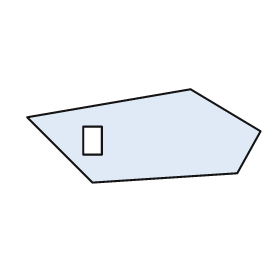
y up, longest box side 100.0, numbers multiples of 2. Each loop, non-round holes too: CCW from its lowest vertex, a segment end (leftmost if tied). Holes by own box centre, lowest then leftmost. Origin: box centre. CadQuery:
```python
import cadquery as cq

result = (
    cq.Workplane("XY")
    .moveTo(-22.0, -20.0)
    .lineTo(40.0, -16.0)
    .lineTo(50.0, 2.0)
    .lineTo(20.0, 20.0)
    .lineTo(-50.0, 8.0)
    .close()
    .moveTo(-26.0, -8.0)
    .lineTo(-18.0, -8.0)
    .lineTo(-18.0, 4.0)
    .lineTo(-26.0, 4.0)
    .close()
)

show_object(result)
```